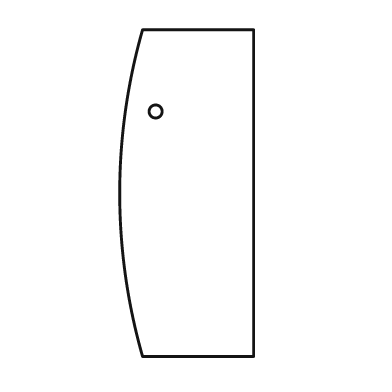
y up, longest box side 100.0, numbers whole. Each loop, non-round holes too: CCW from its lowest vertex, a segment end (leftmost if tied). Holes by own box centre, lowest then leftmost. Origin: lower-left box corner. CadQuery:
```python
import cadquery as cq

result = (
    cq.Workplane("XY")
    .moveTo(7.0, 0.0)
    .lineTo(41.0, 0.0)
    .lineTo(41.0, 100.0)
    .lineTo(7.0, 100.0)
    .threePointArc((0.0, 50.0), (7.0, 0.0))
    .close()
    .moveTo(11.0, 75.0)
    .circle(2.0)
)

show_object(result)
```